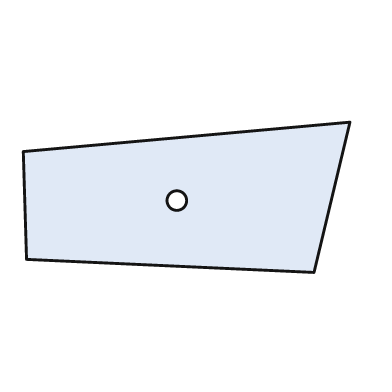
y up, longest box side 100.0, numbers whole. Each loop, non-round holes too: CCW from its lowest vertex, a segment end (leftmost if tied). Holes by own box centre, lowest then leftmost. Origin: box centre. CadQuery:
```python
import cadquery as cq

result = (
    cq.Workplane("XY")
    .moveTo(39.0, -23.0)
    .lineTo(50.0, 23.0)
    .lineTo(-50.0, 14.0)
    .lineTo(-49.0, -19.0)
    .close()
    .moveTo(-3.0, -1.0)
    .circle(3.0)
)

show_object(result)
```